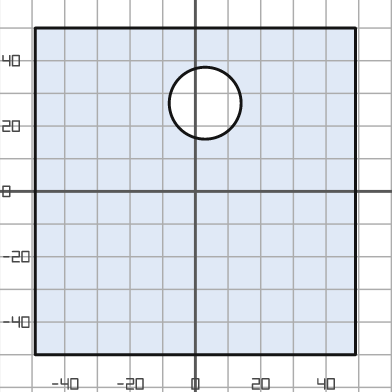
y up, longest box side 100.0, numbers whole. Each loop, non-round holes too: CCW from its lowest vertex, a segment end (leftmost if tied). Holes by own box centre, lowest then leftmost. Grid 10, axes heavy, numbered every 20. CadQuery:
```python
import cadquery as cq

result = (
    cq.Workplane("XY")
    .moveTo(-49.0, -50.0)
    .lineTo(49.0, -50.0)
    .lineTo(49.0, 50.0)
    .lineTo(-49.0, 50.0)
    .close()
    .moveTo(3.0, 27.0)
    .circle(11.0)
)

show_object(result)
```